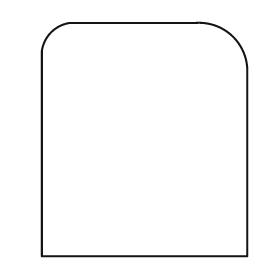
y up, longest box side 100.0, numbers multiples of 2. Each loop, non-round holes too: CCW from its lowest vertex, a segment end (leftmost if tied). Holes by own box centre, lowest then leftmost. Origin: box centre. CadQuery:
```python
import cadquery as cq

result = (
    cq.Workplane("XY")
    .moveTo(-44.0, -50.0)
    .lineTo(44.0, -50.0)
    .lineTo(44.0, 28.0)
    .threePointArc((38.0, 44.0), (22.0, 50.0))
    .lineTo(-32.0, 50.0)
    .threePointArc((-40.0, 46.0), (-44.0, 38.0))
    .close()
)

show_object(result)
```